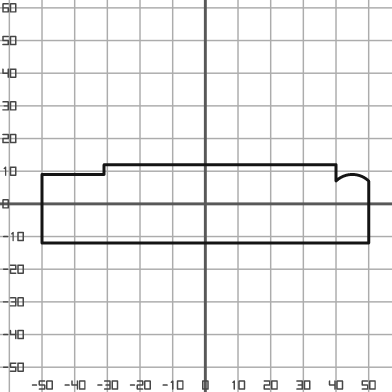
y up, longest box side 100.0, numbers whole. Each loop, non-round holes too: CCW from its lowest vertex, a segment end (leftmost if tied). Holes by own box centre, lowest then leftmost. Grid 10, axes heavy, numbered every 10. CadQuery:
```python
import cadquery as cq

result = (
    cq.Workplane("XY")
    .moveTo(-50.0, -12.0)
    .lineTo(50.0, -12.0)
    .lineTo(50.0, 7.0)
    .threePointArc((45.0, 9.0), (40.0, 7.0))
    .lineTo(40.0, 12.0)
    .lineTo(-31.0, 12.0)
    .lineTo(-31.0, 9.0)
    .lineTo(-50.0, 9.0)
    .close()
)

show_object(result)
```